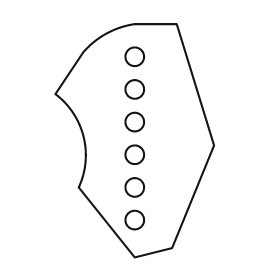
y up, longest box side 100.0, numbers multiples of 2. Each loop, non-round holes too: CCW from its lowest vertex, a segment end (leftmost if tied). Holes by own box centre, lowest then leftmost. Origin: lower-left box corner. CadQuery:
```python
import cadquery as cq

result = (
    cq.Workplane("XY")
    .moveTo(34.0, 0.0)
    .lineTo(50.0, 4.0)
    .lineTo(68.0, 48.0)
    .lineTo(52.0, 100.0)
    .lineTo(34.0, 100.0)
    .threePointArc((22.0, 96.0), (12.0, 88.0))
    .lineTo(0.0, 70.0)
    .threePointArc((12.0, 52.0), (10.0, 30.0))
    .close()
    .moveTo(34.0, 16.0)
    .circle(4.0)
    .moveTo(34.0, 30.0)
    .circle(4.0)
    .moveTo(34.0, 44.0)
    .circle(4.0)
    .moveTo(34.0, 58.0)
    .circle(4.0)
    .moveTo(34.0, 72.0)
    .circle(4.0)
    .moveTo(34.0, 86.0)
    .circle(4.0)
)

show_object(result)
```